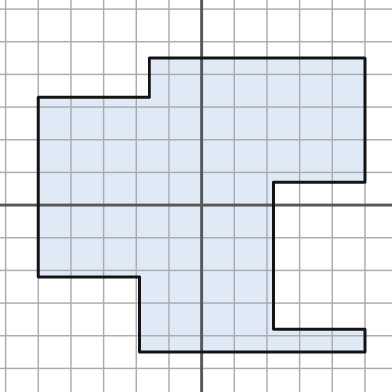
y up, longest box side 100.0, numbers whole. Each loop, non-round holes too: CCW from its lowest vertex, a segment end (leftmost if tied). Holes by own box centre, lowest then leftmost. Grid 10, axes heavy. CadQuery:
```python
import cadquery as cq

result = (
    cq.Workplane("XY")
    .moveTo(-19.0, -45.0)
    .lineTo(50.0, -45.0)
    .lineTo(50.0, -38.0)
    .lineTo(22.0, -38.0)
    .lineTo(22.0, 7.0)
    .lineTo(50.0, 7.0)
    .lineTo(50.0, 45.0)
    .lineTo(-16.0, 45.0)
    .lineTo(-16.0, 33.0)
    .lineTo(-50.0, 33.0)
    .lineTo(-50.0, -22.0)
    .lineTo(-19.0, -22.0)
    .close()
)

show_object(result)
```